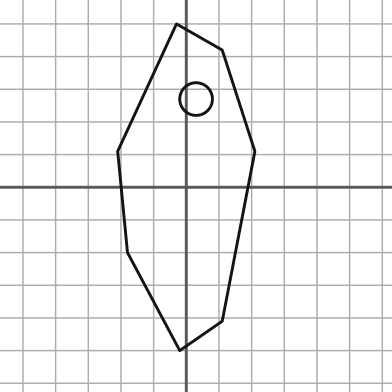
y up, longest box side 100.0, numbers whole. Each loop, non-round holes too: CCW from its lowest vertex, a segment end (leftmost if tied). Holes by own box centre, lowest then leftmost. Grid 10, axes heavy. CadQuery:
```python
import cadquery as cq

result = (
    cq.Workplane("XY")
    .moveTo(-2.0, -50.0)
    .lineTo(11.0, -41.0)
    .lineTo(21.0, 11.0)
    .lineTo(11.0, 42.0)
    .lineTo(-3.0, 50.0)
    .lineTo(-21.0, 11.0)
    .lineTo(-18.0, -20.0)
    .close()
    .moveTo(3.0, 27.0)
    .circle(5.0)
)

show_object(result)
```